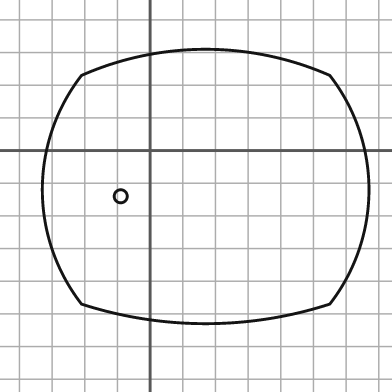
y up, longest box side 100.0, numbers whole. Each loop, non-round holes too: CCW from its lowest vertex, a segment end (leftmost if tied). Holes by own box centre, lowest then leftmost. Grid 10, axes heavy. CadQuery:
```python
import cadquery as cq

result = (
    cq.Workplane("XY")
    .moveTo(-21.0, -47.0)
    .threePointArc((17.0, -53.0), (55.0, -47.0))
    .threePointArc((67.0, -12.0), (55.0, 23.0))
    .threePointArc((17.0, 31.0), (-21.0, 23.0))
    .threePointArc((-33.0, -12.0), (-21.0, -47.0))
    .close()
    .moveTo(-9.0, -14.0)
    .circle(2.0)
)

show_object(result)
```